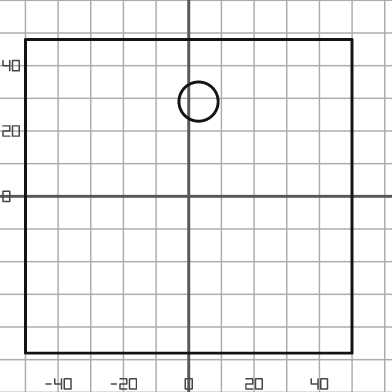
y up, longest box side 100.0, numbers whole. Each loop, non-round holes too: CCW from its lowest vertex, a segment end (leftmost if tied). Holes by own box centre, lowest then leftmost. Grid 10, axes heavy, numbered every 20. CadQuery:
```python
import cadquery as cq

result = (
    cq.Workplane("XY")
    .moveTo(-50.0, -48.0)
    .lineTo(50.0, -48.0)
    .lineTo(50.0, 48.0)
    .lineTo(-50.0, 48.0)
    .close()
    .moveTo(3.0, 29.0)
    .circle(6.0)
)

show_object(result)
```